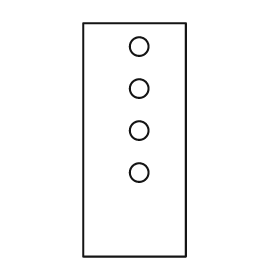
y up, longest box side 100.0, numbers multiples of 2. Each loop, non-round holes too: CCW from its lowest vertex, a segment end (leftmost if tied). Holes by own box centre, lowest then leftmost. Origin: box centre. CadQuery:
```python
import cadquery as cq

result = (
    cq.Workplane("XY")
    .moveTo(-22.0, -50.0)
    .lineTo(22.0, -50.0)
    .lineTo(22.0, 50.0)
    .lineTo(-22.0, 50.0)
    .close()
    .moveTo(2.0, -14.0)
    .circle(4.0)
    .moveTo(2.0, 4.0)
    .circle(4.0)
    .moveTo(2.0, 22.0)
    .circle(4.0)
    .moveTo(2.0, 40.0)
    .circle(4.0)
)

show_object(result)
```